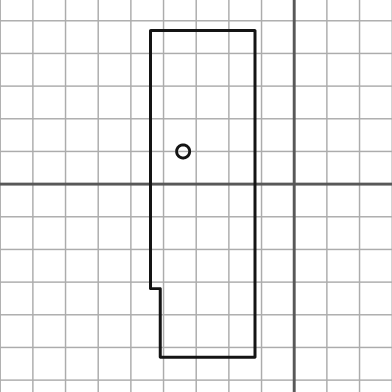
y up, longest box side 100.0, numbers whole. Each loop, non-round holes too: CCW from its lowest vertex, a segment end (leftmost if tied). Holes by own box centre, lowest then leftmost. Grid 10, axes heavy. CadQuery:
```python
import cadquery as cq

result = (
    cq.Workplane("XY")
    .moveTo(-41.0, -53.0)
    .lineTo(-12.0, -53.0)
    .lineTo(-12.0, 47.0)
    .lineTo(-44.0, 47.0)
    .lineTo(-44.0, -32.0)
    .lineTo(-41.0, -32.0)
    .close()
    .moveTo(-34.0, 10.0)
    .circle(2.0)
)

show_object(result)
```